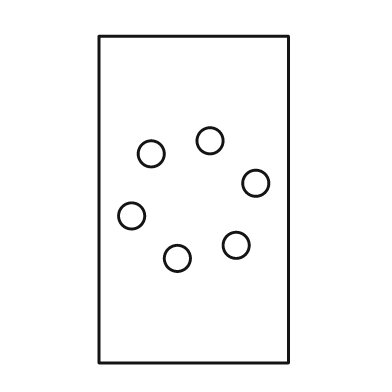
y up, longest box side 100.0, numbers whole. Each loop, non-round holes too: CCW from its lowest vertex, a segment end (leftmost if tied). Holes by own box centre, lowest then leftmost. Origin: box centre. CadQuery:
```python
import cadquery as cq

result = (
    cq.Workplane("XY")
    .moveTo(-29.0, -50.0)
    .lineTo(29.0, -50.0)
    .lineTo(29.0, 50.0)
    .lineTo(-29.0, 50.0)
    .close()
    .moveTo(-5.0, -18.0)
    .circle(4.0)
    .moveTo(13.0, -14.0)
    .circle(4.0)
    .moveTo(-19.0, -5.0)
    .circle(4.0)
    .moveTo(19.0, 5.0)
    .circle(4.0)
    .moveTo(-13.0, 14.0)
    .circle(4.0)
    .moveTo(5.0, 18.0)
    .circle(4.0)
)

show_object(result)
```